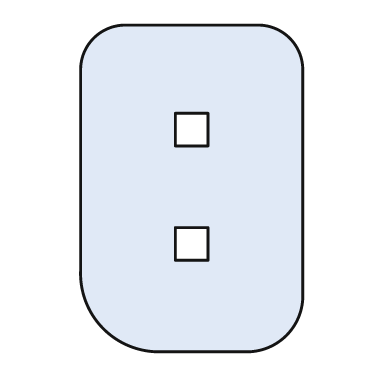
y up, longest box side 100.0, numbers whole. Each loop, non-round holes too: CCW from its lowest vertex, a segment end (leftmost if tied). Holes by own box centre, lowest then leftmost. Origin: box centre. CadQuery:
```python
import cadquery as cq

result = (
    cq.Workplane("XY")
    .moveTo(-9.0, -50.0)
    .lineTo(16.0, -50.0)
    .threePointArc((29.0, -45.0), (34.0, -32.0))
    .lineTo(34.0, 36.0)
    .threePointArc((30.0, 46.0), (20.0, 50.0))
    .lineTo(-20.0, 50.0)
    .threePointArc((-30.0, 46.0), (-34.0, 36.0))
    .lineTo(-34.0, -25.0)
    .threePointArc((-27.0, -43.0), (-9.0, -50.0))
    .close()
    .moveTo(-5.0, -22.0)
    .lineTo(5.0, -22.0)
    .lineTo(5.0, -12.0)
    .lineTo(-5.0, -12.0)
    .close()
    .moveTo(-5.0, 13.0)
    .lineTo(5.0, 13.0)
    .lineTo(5.0, 23.0)
    .lineTo(-5.0, 23.0)
    .close()
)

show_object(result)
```